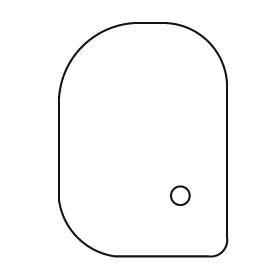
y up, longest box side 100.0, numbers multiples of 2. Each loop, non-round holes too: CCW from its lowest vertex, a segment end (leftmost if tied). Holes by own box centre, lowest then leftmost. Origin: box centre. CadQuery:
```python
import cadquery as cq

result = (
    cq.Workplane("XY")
    .moveTo(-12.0, -50.0)
    .lineTo(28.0, -50.0)
    .threePointArc((34.0, -48.0), (36.0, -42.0))
    .lineTo(36.0, 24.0)
    .threePointArc((28.0, 42.0), (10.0, 50.0))
    .lineTo(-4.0, 50.0)
    .threePointArc((-26.0, 40.0), (-36.0, 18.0))
    .lineTo(-36.0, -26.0)
    .threePointArc((-28.0, -42.0), (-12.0, -50.0))
    .close()
    .moveTo(16.0, -24.0)
    .circle(4.0)
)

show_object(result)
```